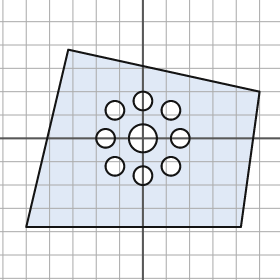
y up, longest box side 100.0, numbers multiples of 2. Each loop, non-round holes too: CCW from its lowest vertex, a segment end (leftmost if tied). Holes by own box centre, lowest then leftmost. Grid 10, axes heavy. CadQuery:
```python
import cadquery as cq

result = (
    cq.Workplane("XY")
    .moveTo(-50.0, -38.0)
    .lineTo(42.0, -38.0)
    .lineTo(50.0, 20.0)
    .lineTo(-32.0, 38.0)
    .close()
    .moveTo(0.0, -16.0)
    .circle(4.0)
    .moveTo(-12.0, -12.0)
    .circle(4.0)
    .moveTo(12.0, -12.0)
    .circle(4.0)
    .moveTo(-16.0, 0.0)
    .circle(4.0)
    .moveTo(0.0, 0.0)
    .circle(6.0)
    .moveTo(16.0, 0.0)
    .circle(4.0)
    .moveTo(-12.0, 12.0)
    .circle(4.0)
    .moveTo(12.0, 12.0)
    .circle(4.0)
    .moveTo(0.0, 16.0)
    .circle(4.0)
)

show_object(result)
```